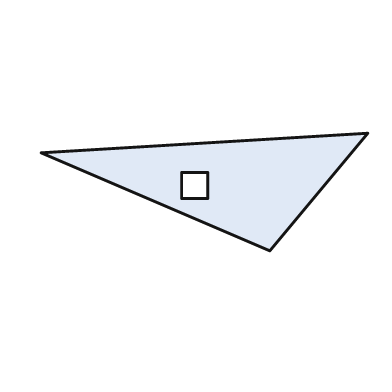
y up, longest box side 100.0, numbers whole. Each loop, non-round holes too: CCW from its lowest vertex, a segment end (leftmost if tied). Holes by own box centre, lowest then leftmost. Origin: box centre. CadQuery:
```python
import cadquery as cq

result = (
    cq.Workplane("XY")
    .moveTo(20.0, -18.0)
    .lineTo(50.0, 18.0)
    .lineTo(-50.0, 12.0)
    .close()
    .moveTo(-7.0, -2.0)
    .lineTo(1.0, -2.0)
    .lineTo(1.0, 6.0)
    .lineTo(-7.0, 6.0)
    .close()
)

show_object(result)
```